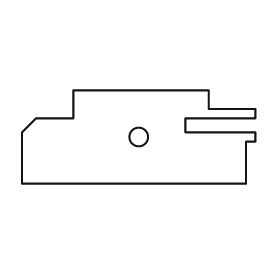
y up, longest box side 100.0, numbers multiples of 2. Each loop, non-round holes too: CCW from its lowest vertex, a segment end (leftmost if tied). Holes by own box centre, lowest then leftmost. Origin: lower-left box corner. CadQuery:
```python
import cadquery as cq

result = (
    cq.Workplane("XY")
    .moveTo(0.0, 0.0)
    .lineTo(96.0, 0.0)
    .lineTo(96.0, 18.0)
    .lineTo(100.0, 18.0)
    .lineTo(100.0, 22.0)
    .lineTo(70.0, 22.0)
    .lineTo(70.0, 28.0)
    .lineTo(100.0, 28.0)
    .lineTo(100.0, 32.0)
    .lineTo(80.0, 32.0)
    .lineTo(80.0, 40.0)
    .lineTo(22.0, 40.0)
    .lineTo(22.0, 28.0)
    .lineTo(6.0, 28.0)
    .lineTo(0.0, 22.0)
    .close()
    .moveTo(50.0, 20.0)
    .circle(4.0)
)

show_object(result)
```